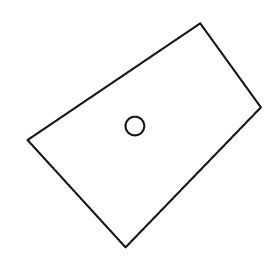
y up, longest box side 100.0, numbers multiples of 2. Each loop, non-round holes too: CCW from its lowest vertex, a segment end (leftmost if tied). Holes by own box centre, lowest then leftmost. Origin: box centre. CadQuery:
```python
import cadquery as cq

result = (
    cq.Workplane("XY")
    .moveTo(-8.0, -48.0)
    .lineTo(50.0, 12.0)
    .lineTo(24.0, 48.0)
    .lineTo(-50.0, -2.0)
    .close()
    .moveTo(-4.0, 4.0)
    .circle(4.0)
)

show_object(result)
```